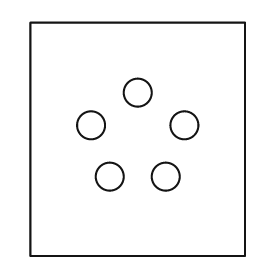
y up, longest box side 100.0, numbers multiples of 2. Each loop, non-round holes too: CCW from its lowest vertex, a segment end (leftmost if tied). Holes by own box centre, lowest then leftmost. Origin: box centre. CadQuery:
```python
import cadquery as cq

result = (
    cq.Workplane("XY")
    .moveTo(-46.0, -50.0)
    .lineTo(46.0, -50.0)
    .lineTo(46.0, 50.0)
    .lineTo(-46.0, 50.0)
    .close()
    .moveTo(-12.0, -16.0)
    .circle(6.0)
    .moveTo(12.0, -16.0)
    .circle(6.0)
    .moveTo(-20.0, 6.0)
    .circle(6.0)
    .moveTo(20.0, 6.0)
    .circle(6.0)
    .moveTo(0.0, 20.0)
    .circle(6.0)
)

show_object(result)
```